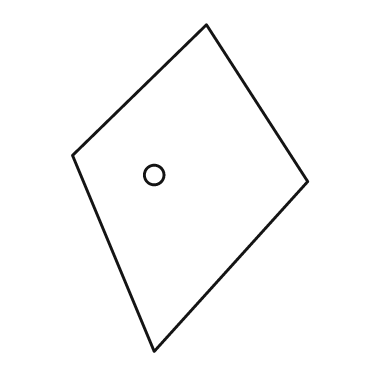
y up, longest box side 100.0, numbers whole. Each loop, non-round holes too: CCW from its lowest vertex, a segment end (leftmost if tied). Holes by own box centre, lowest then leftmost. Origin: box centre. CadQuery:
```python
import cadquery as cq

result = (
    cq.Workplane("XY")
    .moveTo(-11.0, -50.0)
    .lineTo(36.0, 2.0)
    .lineTo(5.0, 50.0)
    .lineTo(-36.0, 10.0)
    .close()
    .moveTo(-11.0, 4.0)
    .circle(3.0)
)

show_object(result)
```